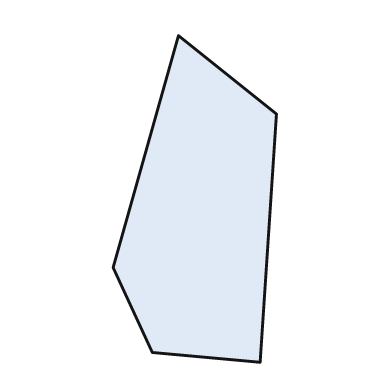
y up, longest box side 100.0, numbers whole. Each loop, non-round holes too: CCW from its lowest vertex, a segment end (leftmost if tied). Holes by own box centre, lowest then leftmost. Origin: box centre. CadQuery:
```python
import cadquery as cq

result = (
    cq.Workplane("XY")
    .moveTo(20.0, -50.0)
    .lineTo(25.0, 26.0)
    .lineTo(-5.0, 50.0)
    .lineTo(-25.0, -21.0)
    .lineTo(-13.0, -47.0)
    .close()
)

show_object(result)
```